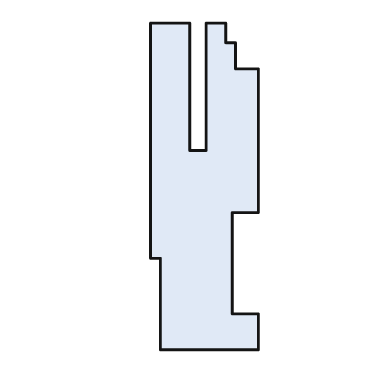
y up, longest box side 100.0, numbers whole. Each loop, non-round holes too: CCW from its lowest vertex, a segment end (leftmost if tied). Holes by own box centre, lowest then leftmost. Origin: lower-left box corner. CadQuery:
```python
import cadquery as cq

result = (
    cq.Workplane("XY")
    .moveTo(3.0, 0.0)
    .lineTo(33.0, 0.0)
    .lineTo(33.0, 11.0)
    .lineTo(25.0, 11.0)
    .lineTo(25.0, 42.0)
    .lineTo(33.0, 42.0)
    .lineTo(33.0, 86.0)
    .lineTo(26.0, 86.0)
    .lineTo(26.0, 94.0)
    .lineTo(23.0, 94.0)
    .lineTo(23.0, 100.0)
    .lineTo(17.0, 100.0)
    .lineTo(17.0, 61.0)
    .lineTo(12.0, 61.0)
    .lineTo(12.0, 100.0)
    .lineTo(0.0, 100.0)
    .lineTo(0.0, 28.0)
    .lineTo(3.0, 28.0)
    .close()
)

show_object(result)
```